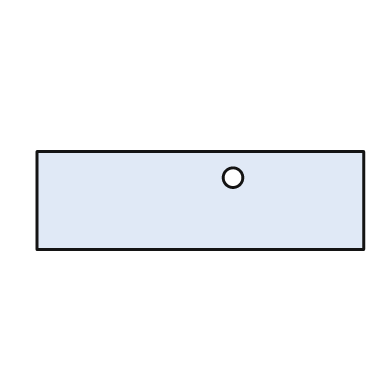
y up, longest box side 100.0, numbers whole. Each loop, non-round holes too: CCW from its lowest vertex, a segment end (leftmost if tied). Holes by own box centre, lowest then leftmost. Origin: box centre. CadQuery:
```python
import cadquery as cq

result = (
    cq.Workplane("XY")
    .moveTo(-50.0, -15.0)
    .lineTo(50.0, -15.0)
    .lineTo(50.0, 15.0)
    .lineTo(-50.0, 15.0)
    .close()
    .moveTo(10.0, 7.0)
    .circle(3.0)
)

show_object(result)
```